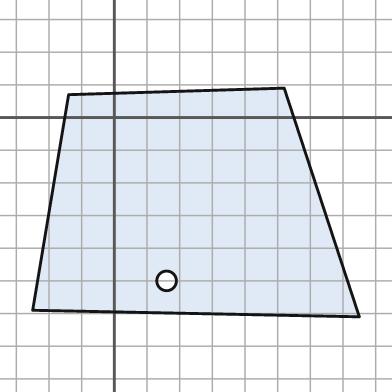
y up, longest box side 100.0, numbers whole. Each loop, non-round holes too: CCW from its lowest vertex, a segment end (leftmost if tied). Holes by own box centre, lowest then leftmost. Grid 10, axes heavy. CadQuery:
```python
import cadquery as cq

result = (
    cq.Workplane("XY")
    .moveTo(75.0, -61.0)
    .lineTo(52.0, 9.0)
    .lineTo(-14.0, 7.0)
    .lineTo(-25.0, -59.0)
    .close()
    .moveTo(16.0, -50.0)
    .circle(3.0)
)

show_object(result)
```